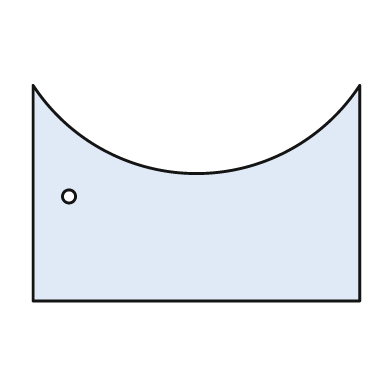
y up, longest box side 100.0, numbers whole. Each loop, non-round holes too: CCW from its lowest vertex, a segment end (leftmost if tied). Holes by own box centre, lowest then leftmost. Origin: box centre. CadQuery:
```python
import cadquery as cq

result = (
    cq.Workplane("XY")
    .moveTo(-50.0, -33.0)
    .lineTo(50.0, -33.0)
    .lineTo(50.0, 33.0)
    .threePointArc((0.0, 6.0), (-50.0, 33.0))
    .close()
    .moveTo(-39.0, -1.0)
    .circle(2.0)
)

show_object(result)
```